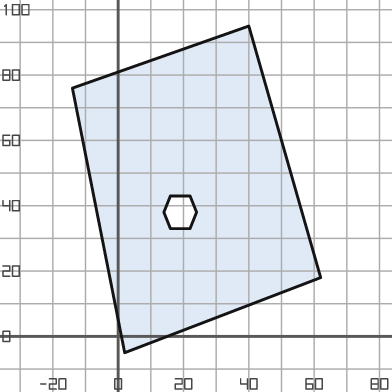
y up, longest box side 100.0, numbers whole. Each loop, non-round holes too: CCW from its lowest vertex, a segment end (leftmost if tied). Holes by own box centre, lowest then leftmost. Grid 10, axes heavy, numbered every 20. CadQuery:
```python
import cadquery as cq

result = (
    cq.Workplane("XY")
    .moveTo(2.0, -5.0)
    .lineTo(62.0, 18.0)
    .lineTo(40.0, 95.0)
    .lineTo(-14.0, 76.0)
    .close()
    .moveTo(16.0, 33.0)
    .lineTo(22.0, 33.0)
    .lineTo(24.0, 38.0)
    .lineTo(22.0, 43.0)
    .lineTo(16.0, 43.0)
    .lineTo(14.0, 38.0)
    .close()
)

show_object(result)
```